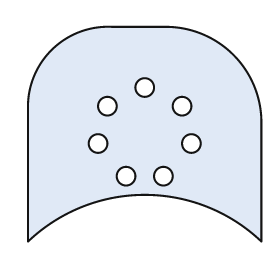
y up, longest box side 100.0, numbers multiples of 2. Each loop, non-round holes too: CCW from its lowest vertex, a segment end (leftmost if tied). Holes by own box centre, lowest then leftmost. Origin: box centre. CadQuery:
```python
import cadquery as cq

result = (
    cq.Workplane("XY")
    .moveTo(-50.0, -46.0)
    .threePointArc((0.0, -26.0), (50.0, -46.0))
    .lineTo(50.0, 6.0)
    .threePointArc((38.0, 34.0), (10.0, 46.0))
    .lineTo(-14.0, 46.0)
    .threePointArc((-40.0, 36.0), (-50.0, 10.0))
    .close()
    .moveTo(-8.0, -18.0)
    .circle(4.0)
    .moveTo(8.0, -18.0)
    .circle(4.0)
    .moveTo(-20.0, -4.0)
    .circle(4.0)
    .moveTo(20.0, -4.0)
    .circle(4.0)
    .moveTo(-16.0, 12.0)
    .circle(4.0)
    .moveTo(16.0, 12.0)
    .circle(4.0)
    .moveTo(0.0, 20.0)
    .circle(4.0)
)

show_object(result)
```